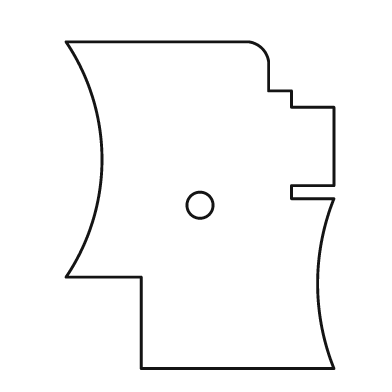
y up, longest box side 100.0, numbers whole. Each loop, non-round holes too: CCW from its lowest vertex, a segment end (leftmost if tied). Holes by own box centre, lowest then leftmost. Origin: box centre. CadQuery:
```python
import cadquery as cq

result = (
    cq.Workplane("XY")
    .moveTo(-18.0, -50.0)
    .lineTo(41.0, -50.0)
    .threePointArc((36.0, -24.0), (41.0, 2.0))
    .lineTo(28.0, 2.0)
    .lineTo(28.0, 6.0)
    .lineTo(41.0, 6.0)
    .lineTo(41.0, 30.0)
    .lineTo(28.0, 30.0)
    .lineTo(28.0, 35.0)
    .lineTo(21.0, 35.0)
    .lineTo(21.0, 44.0)
    .threePointArc((19.0, 48.0), (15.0, 50.0))
    .lineTo(-41.0, 50.0)
    .threePointArc((-30.0, 14.0), (-41.0, -22.0))
    .lineTo(-18.0, -22.0)
    .close()
    .moveTo(0.0, 0.0)
    .circle(4.0)
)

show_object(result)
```